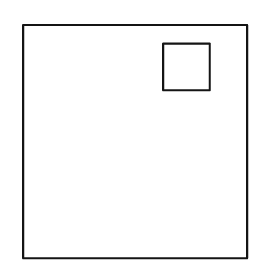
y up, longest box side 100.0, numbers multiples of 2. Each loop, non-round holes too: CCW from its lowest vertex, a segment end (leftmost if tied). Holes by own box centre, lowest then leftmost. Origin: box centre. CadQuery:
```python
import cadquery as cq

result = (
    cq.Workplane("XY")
    .moveTo(-48.0, -50.0)
    .lineTo(48.0, -50.0)
    .lineTo(48.0, 50.0)
    .lineTo(-48.0, 50.0)
    .close()
    .moveTo(12.0, 22.0)
    .lineTo(32.0, 22.0)
    .lineTo(32.0, 42.0)
    .lineTo(12.0, 42.0)
    .close()
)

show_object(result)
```